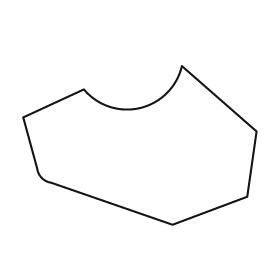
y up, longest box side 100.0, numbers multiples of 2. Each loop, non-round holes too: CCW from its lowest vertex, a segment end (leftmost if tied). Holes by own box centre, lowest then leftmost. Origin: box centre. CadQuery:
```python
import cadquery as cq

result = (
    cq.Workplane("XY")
    .moveTo(14.0, -34.0)
    .lineTo(46.0, -22.0)
    .lineTo(50.0, 6.0)
    .lineTo(18.0, 34.0)
    .threePointArc((0.0, 16.0), (-24.0, 24.0))
    .lineTo(-50.0, 12.0)
    .lineTo(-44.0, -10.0)
    .threePointArc((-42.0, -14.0), (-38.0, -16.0))
    .close()
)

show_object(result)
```